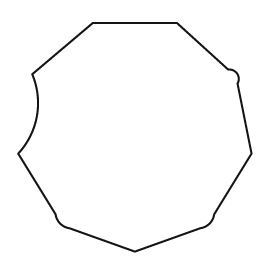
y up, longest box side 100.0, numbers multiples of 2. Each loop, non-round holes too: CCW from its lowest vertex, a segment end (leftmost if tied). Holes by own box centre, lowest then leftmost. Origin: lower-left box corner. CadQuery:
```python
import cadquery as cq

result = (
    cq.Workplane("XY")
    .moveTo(50.0, 0.0)
    .lineTo(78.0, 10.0)
    .threePointArc((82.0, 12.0), (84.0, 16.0))
    .lineTo(100.0, 42.0)
    .lineTo(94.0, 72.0)
    .threePointArc((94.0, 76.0), (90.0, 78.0))
    .lineTo(68.0, 98.0)
    .lineTo(32.0, 98.0)
    .lineTo(6.0, 76.0)
    .threePointArc((8.0, 58.0), (0.0, 42.0))
    .lineTo(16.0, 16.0)
    .threePointArc((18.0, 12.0), (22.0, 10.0))
    .close()
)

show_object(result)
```